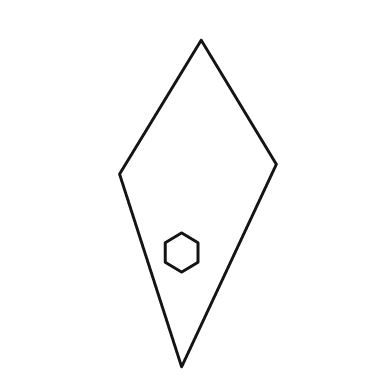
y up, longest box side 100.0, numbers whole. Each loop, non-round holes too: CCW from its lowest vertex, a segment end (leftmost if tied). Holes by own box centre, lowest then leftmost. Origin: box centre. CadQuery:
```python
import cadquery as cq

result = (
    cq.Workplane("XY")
    .moveTo(-5.0, -50.0)
    .lineTo(24.0, 12.0)
    .lineTo(1.0, 50.0)
    .lineTo(-24.0, 9.0)
    .close()
    .moveTo(-5.0, -21.0)
    .lineTo(0.0, -18.0)
    .lineTo(0.0, -12.0)
    .lineTo(-5.0, -9.0)
    .lineTo(-10.0, -12.0)
    .lineTo(-10.0, -18.0)
    .close()
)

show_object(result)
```